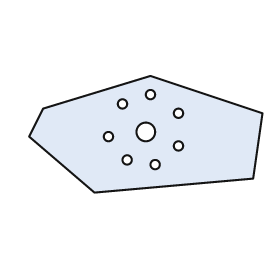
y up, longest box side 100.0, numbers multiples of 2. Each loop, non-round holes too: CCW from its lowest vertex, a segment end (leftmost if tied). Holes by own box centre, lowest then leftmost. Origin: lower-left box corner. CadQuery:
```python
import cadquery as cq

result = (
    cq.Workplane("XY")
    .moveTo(28.0, 0.0)
    .lineTo(96.0, 6.0)
    .lineTo(100.0, 34.0)
    .lineTo(52.0, 50.0)
    .lineTo(6.0, 36.0)
    .lineTo(0.0, 24.0)
    .close()
    .moveTo(54.0, 12.0)
    .circle(2.0)
    .moveTo(42.0, 14.0)
    .circle(2.0)
    .moveTo(64.0, 20.0)
    .circle(2.0)
    .moveTo(34.0, 24.0)
    .circle(2.0)
    .moveTo(50.0, 26.0)
    .circle(4.0)
    .moveTo(64.0, 34.0)
    .circle(2.0)
    .moveTo(40.0, 38.0)
    .circle(2.0)
    .moveTo(52.0, 42.0)
    .circle(2.0)
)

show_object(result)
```